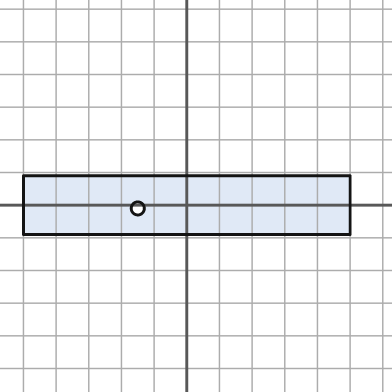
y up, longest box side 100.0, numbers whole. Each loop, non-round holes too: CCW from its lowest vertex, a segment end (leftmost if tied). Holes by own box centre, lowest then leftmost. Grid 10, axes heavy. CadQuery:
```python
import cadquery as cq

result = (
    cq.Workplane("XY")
    .moveTo(-50.0, -9.0)
    .lineTo(50.0, -9.0)
    .lineTo(50.0, 9.0)
    .lineTo(-50.0, 9.0)
    .close()
    .moveTo(-15.0, -1.0)
    .circle(2.0)
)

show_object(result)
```